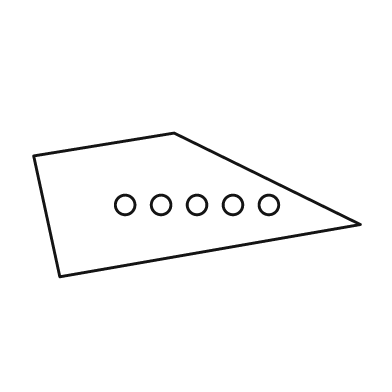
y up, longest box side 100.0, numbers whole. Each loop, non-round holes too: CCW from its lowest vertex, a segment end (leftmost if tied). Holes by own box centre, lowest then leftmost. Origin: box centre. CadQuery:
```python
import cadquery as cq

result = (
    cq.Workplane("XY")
    .moveTo(-42.0, -22.0)
    .lineTo(50.0, -6.0)
    .lineTo(-7.0, 22.0)
    .lineTo(-50.0, 15.0)
    .close()
    .moveTo(-22.0, 0.0)
    .circle(3.0)
    .moveTo(-11.0, 0.0)
    .circle(3.0)
    .moveTo(0.0, 0.0)
    .circle(3.0)
    .moveTo(11.0, 0.0)
    .circle(3.0)
    .moveTo(22.0, 0.0)
    .circle(3.0)
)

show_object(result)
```